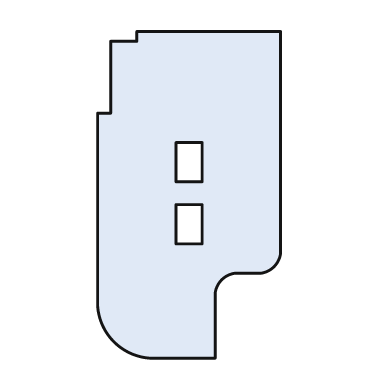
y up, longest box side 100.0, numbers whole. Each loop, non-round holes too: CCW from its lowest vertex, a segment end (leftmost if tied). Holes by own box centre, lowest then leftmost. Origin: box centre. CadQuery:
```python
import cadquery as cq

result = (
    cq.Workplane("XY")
    .moveTo(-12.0, -50.0)
    .lineTo(8.0, -50.0)
    .lineTo(8.0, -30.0)
    .threePointArc((10.0, -26.0), (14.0, -24.0))
    .lineTo(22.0, -24.0)
    .threePointArc((26.0, -22.0), (28.0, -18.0))
    .lineTo(28.0, 50.0)
    .lineTo(-16.0, 50.0)
    .lineTo(-16.0, 47.0)
    .lineTo(-24.0, 47.0)
    .lineTo(-24.0, 25.0)
    .lineTo(-28.0, 25.0)
    .lineTo(-28.0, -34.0)
    .threePointArc((-23.0, -45.0), (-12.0, -50.0))
    .close()
    .moveTo(-4.0, -15.0)
    .lineTo(4.0, -15.0)
    .lineTo(4.0, -3.0)
    .lineTo(-4.0, -3.0)
    .close()
    .moveTo(-4.0, 4.0)
    .lineTo(4.0, 4.0)
    .lineTo(4.0, 16.0)
    .lineTo(-4.0, 16.0)
    .close()
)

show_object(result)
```